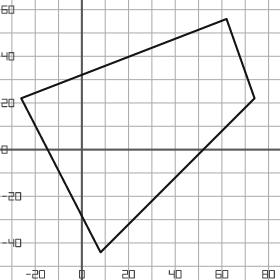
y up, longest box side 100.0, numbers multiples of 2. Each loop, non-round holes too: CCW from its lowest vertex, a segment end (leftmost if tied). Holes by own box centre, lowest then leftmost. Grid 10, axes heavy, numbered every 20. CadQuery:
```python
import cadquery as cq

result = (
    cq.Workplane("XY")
    .moveTo(8.0, -44.0)
    .lineTo(74.0, 22.0)
    .lineTo(62.0, 56.0)
    .lineTo(-26.0, 22.0)
    .close()
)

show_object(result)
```